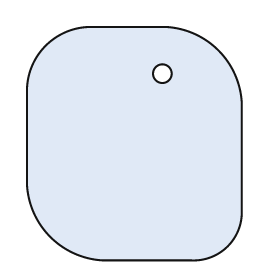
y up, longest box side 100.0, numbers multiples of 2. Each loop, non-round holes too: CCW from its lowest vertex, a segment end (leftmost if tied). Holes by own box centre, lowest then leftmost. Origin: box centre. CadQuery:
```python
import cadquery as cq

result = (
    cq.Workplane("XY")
    .moveTo(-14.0, -50.0)
    .lineTo(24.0, -50.0)
    .threePointArc((40.0, -44.0), (46.0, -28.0))
    .lineTo(46.0, 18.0)
    .threePointArc((36.0, 40.0), (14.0, 50.0))
    .lineTo(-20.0, 50.0)
    .threePointArc((-38.0, 42.0), (-46.0, 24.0))
    .lineTo(-46.0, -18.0)
    .threePointArc((-36.0, -40.0), (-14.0, -50.0))
    .close()
    .moveTo(12.0, 30.0)
    .circle(4.0)
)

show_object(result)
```